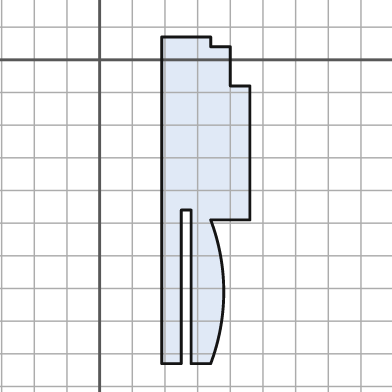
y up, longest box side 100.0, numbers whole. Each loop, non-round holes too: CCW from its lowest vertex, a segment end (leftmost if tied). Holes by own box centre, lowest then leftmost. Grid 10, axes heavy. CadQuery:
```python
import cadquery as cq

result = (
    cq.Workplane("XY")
    .moveTo(19.0, -93.0)
    .lineTo(25.0, -93.0)
    .lineTo(25.0, -46.0)
    .lineTo(28.0, -46.0)
    .lineTo(28.0, -93.0)
    .lineTo(34.0, -93.0)
    .threePointArc((38.0, -71.0), (34.0, -49.0))
    .lineTo(46.0, -49.0)
    .lineTo(46.0, -8.0)
    .lineTo(40.0, -8.0)
    .lineTo(40.0, 4.0)
    .lineTo(34.0, 4.0)
    .lineTo(34.0, 7.0)
    .lineTo(19.0, 7.0)
    .close()
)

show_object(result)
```